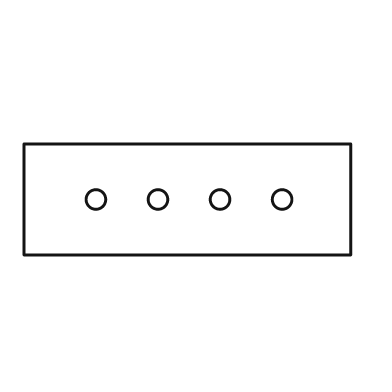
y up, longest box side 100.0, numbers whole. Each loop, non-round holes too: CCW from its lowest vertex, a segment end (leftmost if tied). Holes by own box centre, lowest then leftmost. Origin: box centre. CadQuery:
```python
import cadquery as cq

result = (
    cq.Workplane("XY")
    .moveTo(-50.0, -17.0)
    .lineTo(50.0, -17.0)
    .lineTo(50.0, 17.0)
    .lineTo(-50.0, 17.0)
    .close()
    .moveTo(-28.0, 0.0)
    .circle(3.0)
    .moveTo(-9.0, 0.0)
    .circle(3.0)
    .moveTo(10.0, 0.0)
    .circle(3.0)
    .moveTo(29.0, 0.0)
    .circle(3.0)
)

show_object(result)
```